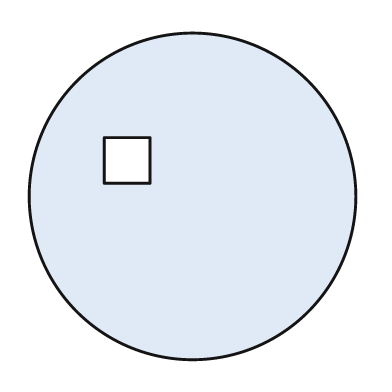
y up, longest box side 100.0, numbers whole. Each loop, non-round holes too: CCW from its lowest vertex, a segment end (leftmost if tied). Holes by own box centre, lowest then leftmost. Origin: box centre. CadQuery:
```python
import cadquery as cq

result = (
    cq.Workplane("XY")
    .moveTo(0.0, 0.0)
    .circle(50.0)
    .moveTo(-27.0, 4.0)
    .lineTo(-13.0, 4.0)
    .lineTo(-13.0, 18.0)
    .lineTo(-27.0, 18.0)
    .close()
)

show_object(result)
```